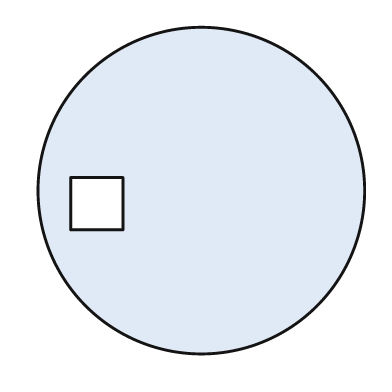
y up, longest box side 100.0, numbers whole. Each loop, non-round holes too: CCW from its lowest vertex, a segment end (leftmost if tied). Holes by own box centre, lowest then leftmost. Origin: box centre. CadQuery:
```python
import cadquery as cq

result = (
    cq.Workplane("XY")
    .moveTo(0.0, 0.0)
    .circle(50.0)
    .moveTo(-40.0, -12.0)
    .lineTo(-24.0, -12.0)
    .lineTo(-24.0, 4.0)
    .lineTo(-40.0, 4.0)
    .close()
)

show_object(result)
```